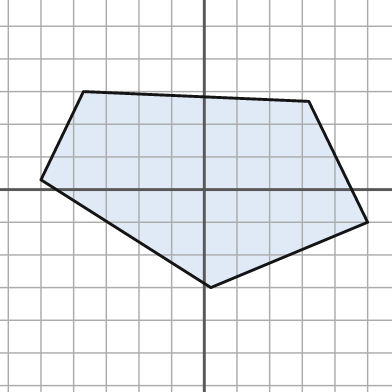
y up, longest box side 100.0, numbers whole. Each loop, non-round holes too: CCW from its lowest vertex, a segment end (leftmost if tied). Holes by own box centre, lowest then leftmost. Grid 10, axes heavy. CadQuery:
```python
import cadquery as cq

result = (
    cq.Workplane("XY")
    .moveTo(2.0, -30.0)
    .lineTo(50.0, -10.0)
    .lineTo(32.0, 27.0)
    .lineTo(-37.0, 30.0)
    .lineTo(-50.0, 3.0)
    .close()
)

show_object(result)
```